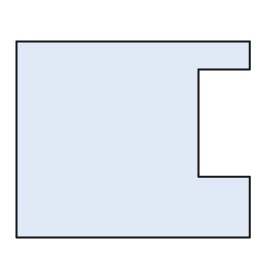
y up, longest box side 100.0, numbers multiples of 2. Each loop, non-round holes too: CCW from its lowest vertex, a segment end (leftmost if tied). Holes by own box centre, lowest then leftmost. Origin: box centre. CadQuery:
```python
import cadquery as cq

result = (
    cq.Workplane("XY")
    .moveTo(-50.0, -42.0)
    .lineTo(50.0, -42.0)
    .lineTo(50.0, -16.0)
    .lineTo(28.0, -16.0)
    .lineTo(28.0, 30.0)
    .lineTo(50.0, 30.0)
    .lineTo(50.0, 42.0)
    .lineTo(-50.0, 42.0)
    .close()
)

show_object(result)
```